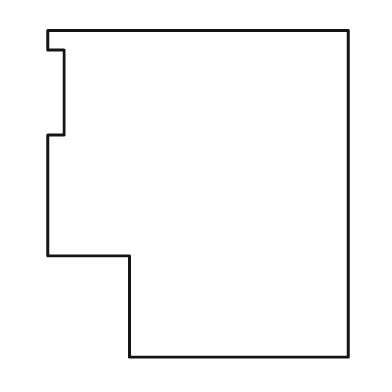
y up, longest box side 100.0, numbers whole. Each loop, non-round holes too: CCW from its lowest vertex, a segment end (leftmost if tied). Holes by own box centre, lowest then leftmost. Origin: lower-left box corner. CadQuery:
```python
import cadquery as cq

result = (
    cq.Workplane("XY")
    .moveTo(25.0, 0.0)
    .lineTo(92.0, 0.0)
    .lineTo(92.0, 100.0)
    .lineTo(0.0, 100.0)
    .lineTo(0.0, 94.0)
    .lineTo(5.0, 94.0)
    .lineTo(5.0, 68.0)
    .lineTo(0.0, 68.0)
    .lineTo(0.0, 31.0)
    .lineTo(25.0, 31.0)
    .close()
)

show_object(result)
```